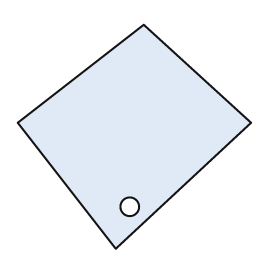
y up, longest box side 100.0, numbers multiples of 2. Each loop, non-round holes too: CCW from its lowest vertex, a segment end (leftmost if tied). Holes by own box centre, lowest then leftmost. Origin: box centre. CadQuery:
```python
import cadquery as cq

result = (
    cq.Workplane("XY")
    .moveTo(-8.0, -48.0)
    .lineTo(50.0, 6.0)
    .lineTo(4.0, 48.0)
    .lineTo(-50.0, 6.0)
    .close()
    .moveTo(-2.0, -30.0)
    .circle(4.0)
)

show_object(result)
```